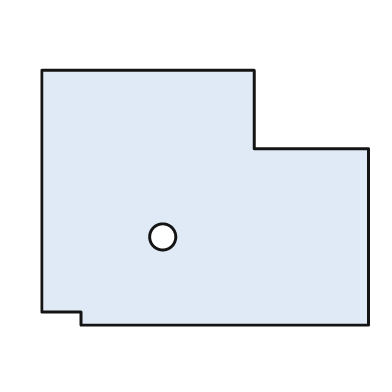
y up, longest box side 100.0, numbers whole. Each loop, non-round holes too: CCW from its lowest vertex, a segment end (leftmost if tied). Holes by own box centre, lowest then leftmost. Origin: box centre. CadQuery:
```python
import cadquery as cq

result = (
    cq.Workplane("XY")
    .moveTo(-38.0, -39.0)
    .lineTo(50.0, -39.0)
    .lineTo(50.0, 15.0)
    .lineTo(15.0, 15.0)
    .lineTo(15.0, 39.0)
    .lineTo(-50.0, 39.0)
    .lineTo(-50.0, -35.0)
    .lineTo(-38.0, -35.0)
    .close()
    .moveTo(-13.0, -12.0)
    .circle(4.0)
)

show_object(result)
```